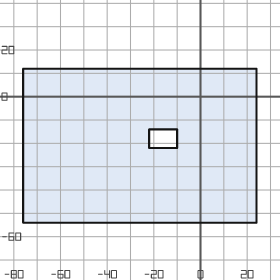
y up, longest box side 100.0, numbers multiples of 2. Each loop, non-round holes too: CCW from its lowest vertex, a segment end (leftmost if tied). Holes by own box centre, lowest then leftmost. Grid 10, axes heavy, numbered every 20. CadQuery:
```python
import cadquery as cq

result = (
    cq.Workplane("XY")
    .moveTo(-76.0, -54.0)
    .lineTo(24.0, -54.0)
    .lineTo(24.0, 12.0)
    .lineTo(-76.0, 12.0)
    .close()
    .moveTo(-22.0, -22.0)
    .lineTo(-10.0, -22.0)
    .lineTo(-10.0, -14.0)
    .lineTo(-22.0, -14.0)
    .close()
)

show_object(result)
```